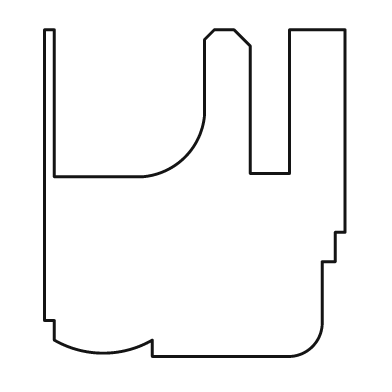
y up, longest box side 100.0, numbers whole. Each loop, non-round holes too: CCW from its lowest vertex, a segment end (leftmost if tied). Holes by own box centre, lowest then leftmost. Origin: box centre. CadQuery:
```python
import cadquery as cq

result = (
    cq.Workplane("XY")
    .moveTo(-13.0, -50.0)
    .lineTo(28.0, -50.0)
    .threePointArc((36.0, -47.0), (39.0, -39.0))
    .lineTo(39.0, -21.0)
    .lineTo(43.0, -21.0)
    .lineTo(43.0, -12.0)
    .lineTo(46.0, -12.0)
    .lineTo(46.0, 50.0)
    .lineTo(29.0, 50.0)
    .lineTo(29.0, 6.0)
    .lineTo(17.0, 6.0)
    .lineTo(17.0, 45.0)
    .lineTo(12.0, 50.0)
    .lineTo(6.0, 50.0)
    .lineTo(3.0, 47.0)
    .lineTo(3.0, 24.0)
    .threePointArc((-3.0, 11.0), (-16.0, 5.0))
    .lineTo(-43.0, 5.0)
    .lineTo(-43.0, 50.0)
    .lineTo(-46.0, 50.0)
    .lineTo(-46.0, -39.0)
    .lineTo(-43.0, -39.0)
    .lineTo(-43.0, -45.0)
    .threePointArc((-28.0, -49.0), (-13.0, -45.0))
    .close()
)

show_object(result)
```